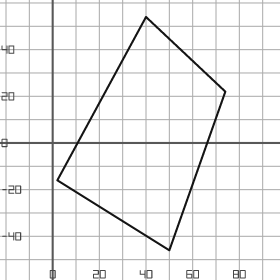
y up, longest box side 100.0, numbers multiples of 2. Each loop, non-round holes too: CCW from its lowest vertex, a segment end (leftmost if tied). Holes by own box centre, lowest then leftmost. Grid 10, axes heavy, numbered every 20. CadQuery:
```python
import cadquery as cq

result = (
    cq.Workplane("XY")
    .moveTo(50.0, -46.0)
    .lineTo(74.0, 22.0)
    .lineTo(40.0, 54.0)
    .lineTo(2.0, -16.0)
    .close()
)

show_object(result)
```